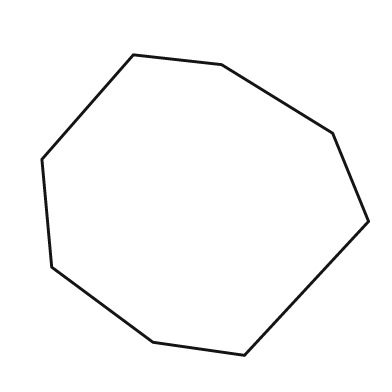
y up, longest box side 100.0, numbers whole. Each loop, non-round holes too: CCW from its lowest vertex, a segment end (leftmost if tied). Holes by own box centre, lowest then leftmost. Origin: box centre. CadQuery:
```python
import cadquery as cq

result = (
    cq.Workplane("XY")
    .moveTo(12.0, -46.0)
    .lineTo(50.0, -5.0)
    .lineTo(39.0, 22.0)
    .lineTo(5.0, 43.0)
    .lineTo(-22.0, 46.0)
    .lineTo(-50.0, 14.0)
    .lineTo(-47.0, -19.0)
    .lineTo(-16.0, -42.0)
    .close()
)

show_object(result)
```